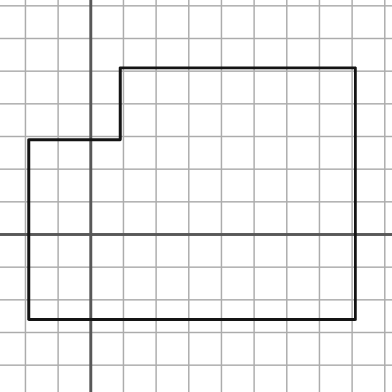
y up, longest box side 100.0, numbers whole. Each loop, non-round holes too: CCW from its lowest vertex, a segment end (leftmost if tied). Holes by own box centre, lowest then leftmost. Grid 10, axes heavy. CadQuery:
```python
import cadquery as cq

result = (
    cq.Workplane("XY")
    .moveTo(-19.0, -26.0)
    .lineTo(81.0, -26.0)
    .lineTo(81.0, 51.0)
    .lineTo(9.0, 51.0)
    .lineTo(9.0, 29.0)
    .lineTo(-19.0, 29.0)
    .close()
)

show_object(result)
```